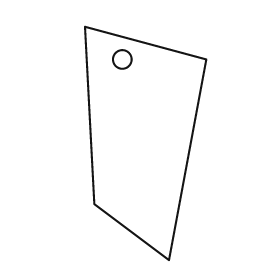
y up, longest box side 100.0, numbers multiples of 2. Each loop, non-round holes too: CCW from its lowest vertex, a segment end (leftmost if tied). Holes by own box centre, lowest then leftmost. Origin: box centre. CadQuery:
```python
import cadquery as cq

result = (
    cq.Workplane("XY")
    .moveTo(10.0, -50.0)
    .lineTo(26.0, 36.0)
    .lineTo(-26.0, 50.0)
    .lineTo(-22.0, -26.0)
    .close()
    .moveTo(-10.0, 36.0)
    .circle(4.0)
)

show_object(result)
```